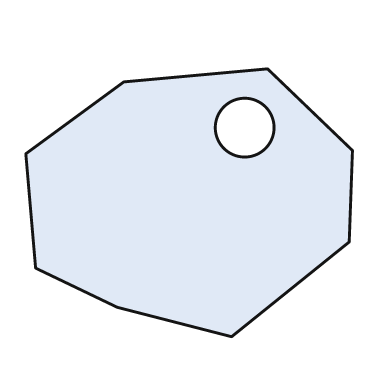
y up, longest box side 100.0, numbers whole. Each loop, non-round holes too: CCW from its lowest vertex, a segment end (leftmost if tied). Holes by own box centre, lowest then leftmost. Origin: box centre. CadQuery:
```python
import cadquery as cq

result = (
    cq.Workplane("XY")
    .moveTo(13.0, -41.0)
    .lineTo(49.0, -12.0)
    .lineTo(50.0, 16.0)
    .lineTo(24.0, 41.0)
    .lineTo(-20.0, 37.0)
    .lineTo(-50.0, 15.0)
    .lineTo(-47.0, -20.0)
    .lineTo(-22.0, -32.0)
    .close()
    .moveTo(17.0, 23.0)
    .circle(9.0)
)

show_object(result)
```